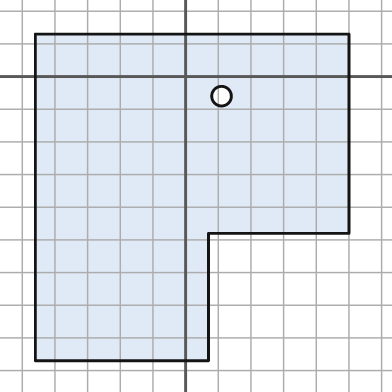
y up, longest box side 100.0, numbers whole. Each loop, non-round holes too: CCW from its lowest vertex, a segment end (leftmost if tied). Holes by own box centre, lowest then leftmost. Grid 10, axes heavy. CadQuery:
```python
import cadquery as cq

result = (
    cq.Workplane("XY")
    .moveTo(-46.0, -87.0)
    .lineTo(7.0, -87.0)
    .lineTo(7.0, -48.0)
    .lineTo(50.0, -48.0)
    .lineTo(50.0, 13.0)
    .lineTo(-46.0, 13.0)
    .close()
    .moveTo(11.0, -6.0)
    .circle(3.0)
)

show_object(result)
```